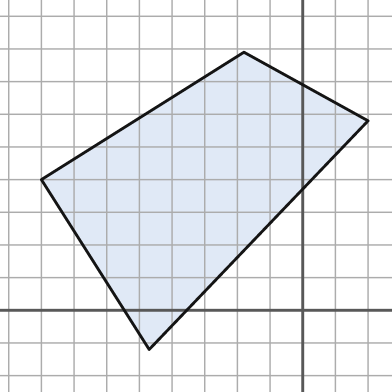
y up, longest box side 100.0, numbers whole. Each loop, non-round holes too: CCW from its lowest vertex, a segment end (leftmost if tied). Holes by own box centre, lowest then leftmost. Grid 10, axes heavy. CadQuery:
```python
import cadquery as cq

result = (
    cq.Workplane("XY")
    .moveTo(-47.0, -12.0)
    .lineTo(20.0, 58.0)
    .lineTo(-18.0, 79.0)
    .lineTo(-80.0, 40.0)
    .close()
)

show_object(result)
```